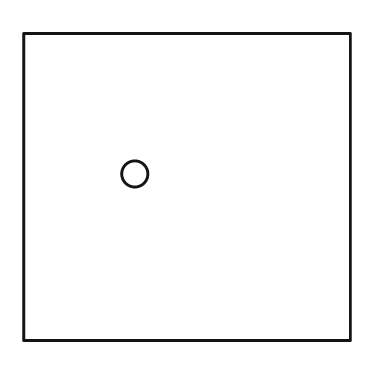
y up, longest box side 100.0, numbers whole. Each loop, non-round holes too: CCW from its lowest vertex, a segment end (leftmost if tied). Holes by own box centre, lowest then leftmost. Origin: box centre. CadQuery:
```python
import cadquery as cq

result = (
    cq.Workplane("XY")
    .moveTo(-50.0, -47.0)
    .lineTo(50.0, -47.0)
    .lineTo(50.0, 47.0)
    .lineTo(-50.0, 47.0)
    .close()
    .moveTo(-16.0, 4.0)
    .circle(4.0)
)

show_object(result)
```